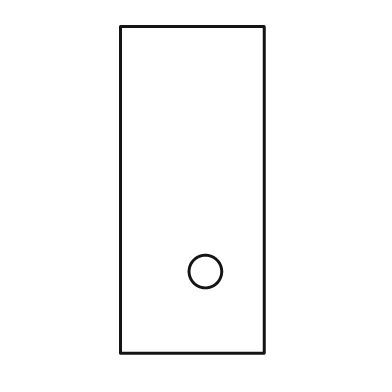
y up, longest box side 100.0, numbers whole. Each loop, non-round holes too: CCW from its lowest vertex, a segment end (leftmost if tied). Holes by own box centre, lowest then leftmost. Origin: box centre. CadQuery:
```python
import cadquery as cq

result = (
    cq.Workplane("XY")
    .moveTo(-22.0, -50.0)
    .lineTo(22.0, -50.0)
    .lineTo(22.0, 50.0)
    .lineTo(-22.0, 50.0)
    .close()
    .moveTo(4.0, -25.0)
    .circle(5.0)
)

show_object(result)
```